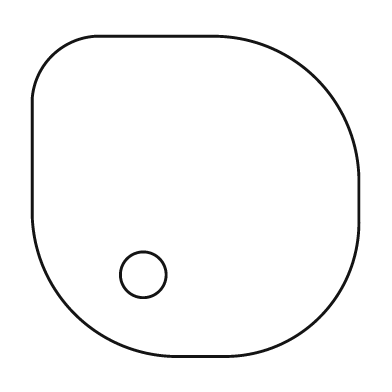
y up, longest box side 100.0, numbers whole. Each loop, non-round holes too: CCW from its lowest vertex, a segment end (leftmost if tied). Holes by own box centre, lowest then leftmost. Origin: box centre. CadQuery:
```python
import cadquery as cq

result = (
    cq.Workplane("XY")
    .moveTo(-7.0, -49.0)
    .lineTo(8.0, -49.0)
    .threePointArc((38.0, -37.0), (50.0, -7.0))
    .lineTo(50.0, 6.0)
    .threePointArc((37.0, 36.0), (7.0, 49.0))
    .lineTo(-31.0, 49.0)
    .threePointArc((-44.0, 43.0), (-50.0, 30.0))
    .lineTo(-50.0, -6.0)
    .threePointArc((-37.0, -36.0), (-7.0, -49.0))
    .close()
    .moveTo(-16.0, -24.0)
    .circle(7.0)
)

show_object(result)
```